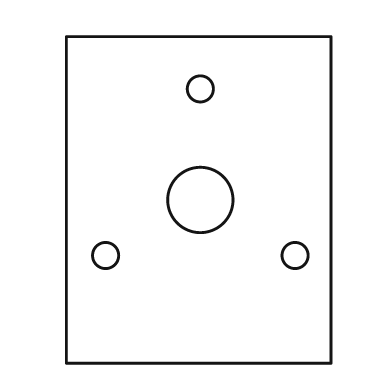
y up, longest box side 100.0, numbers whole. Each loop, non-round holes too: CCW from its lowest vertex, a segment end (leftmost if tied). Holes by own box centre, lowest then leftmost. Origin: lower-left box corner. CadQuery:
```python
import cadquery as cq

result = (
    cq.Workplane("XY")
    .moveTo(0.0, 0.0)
    .lineTo(81.0, 0.0)
    .lineTo(81.0, 100.0)
    .lineTo(0.0, 100.0)
    .close()
    .moveTo(12.0, 33.0)
    .circle(4.0)
    .moveTo(70.0, 33.0)
    .circle(4.0)
    .moveTo(41.0, 50.0)
    .circle(10.0)
    .moveTo(41.0, 84.0)
    .circle(4.0)
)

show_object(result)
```